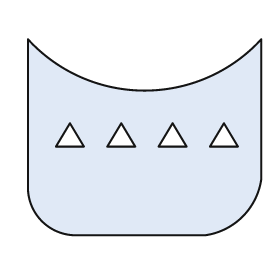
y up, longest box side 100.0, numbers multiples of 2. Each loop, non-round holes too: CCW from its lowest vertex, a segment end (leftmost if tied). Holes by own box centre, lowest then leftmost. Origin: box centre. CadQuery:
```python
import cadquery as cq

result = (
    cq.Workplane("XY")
    .moveTo(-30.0, -42.0)
    .lineTo(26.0, -42.0)
    .threePointArc((42.0, -34.0), (50.0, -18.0))
    .lineTo(50.0, 42.0)
    .threePointArc((0.0, 20.0), (-50.0, 42.0))
    .lineTo(-50.0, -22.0)
    .threePointArc((-44.0, -36.0), (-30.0, -42.0))
    .close()
    .moveTo(-38.0, -4.0)
    .lineTo(-26.0, -4.0)
    .lineTo(-32.0, 6.0)
    .close()
    .moveTo(-16.0, -4.0)
    .lineTo(-4.0, -4.0)
    .lineTo(-10.0, 6.0)
    .close()
    .moveTo(6.0, -4.0)
    .lineTo(18.0, -4.0)
    .lineTo(12.0, 6.0)
    .close()
    .moveTo(28.0, -4.0)
    .lineTo(40.0, -4.0)
    .lineTo(34.0, 6.0)
    .close()
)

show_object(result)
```